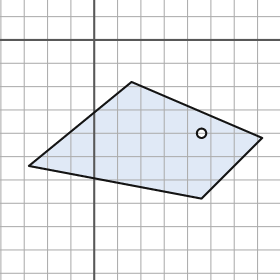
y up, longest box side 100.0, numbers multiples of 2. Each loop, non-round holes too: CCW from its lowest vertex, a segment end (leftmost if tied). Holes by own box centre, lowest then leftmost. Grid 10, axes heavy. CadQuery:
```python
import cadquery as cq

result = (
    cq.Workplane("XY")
    .moveTo(46.0, -68.0)
    .lineTo(72.0, -42.0)
    .lineTo(16.0, -18.0)
    .lineTo(-28.0, -54.0)
    .close()
    .moveTo(46.0, -40.0)
    .circle(2.0)
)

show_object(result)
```